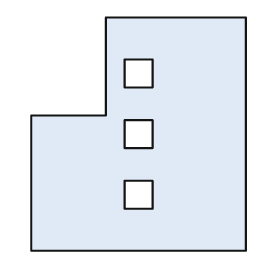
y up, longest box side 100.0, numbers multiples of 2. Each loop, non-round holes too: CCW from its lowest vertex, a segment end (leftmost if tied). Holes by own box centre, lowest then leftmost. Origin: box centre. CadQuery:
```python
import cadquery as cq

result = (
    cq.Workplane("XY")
    .moveTo(-46.0, -50.0)
    .lineTo(46.0, -50.0)
    .lineTo(46.0, 50.0)
    .lineTo(-14.0, 50.0)
    .lineTo(-14.0, 8.0)
    .lineTo(-46.0, 8.0)
    .close()
    .moveTo(-6.0, -32.0)
    .lineTo(6.0, -32.0)
    .lineTo(6.0, -20.0)
    .lineTo(-6.0, -20.0)
    .close()
    .moveTo(-6.0, -6.0)
    .lineTo(6.0, -6.0)
    .lineTo(6.0, 6.0)
    .lineTo(-6.0, 6.0)
    .close()
    .moveTo(-6.0, 20.0)
    .lineTo(6.0, 20.0)
    .lineTo(6.0, 32.0)
    .lineTo(-6.0, 32.0)
    .close()
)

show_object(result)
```